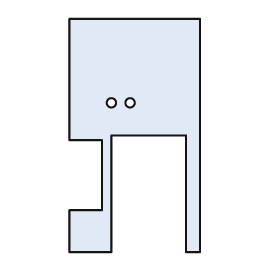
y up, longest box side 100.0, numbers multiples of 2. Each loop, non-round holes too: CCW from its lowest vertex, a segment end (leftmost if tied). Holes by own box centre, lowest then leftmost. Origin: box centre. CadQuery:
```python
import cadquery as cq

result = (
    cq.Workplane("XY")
    .moveTo(-28.0, -50.0)
    .lineTo(-10.0, -50.0)
    .lineTo(-10.0, 0.0)
    .lineTo(22.0, 0.0)
    .lineTo(22.0, -50.0)
    .lineTo(28.0, -50.0)
    .lineTo(28.0, 50.0)
    .lineTo(-28.0, 50.0)
    .lineTo(-28.0, -2.0)
    .lineTo(-14.0, -2.0)
    .lineTo(-14.0, -32.0)
    .lineTo(-28.0, -32.0)
    .close()
    .moveTo(-10.0, 14.0)
    .circle(2.0)
    .moveTo(-2.0, 14.0)
    .circle(2.0)
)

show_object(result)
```